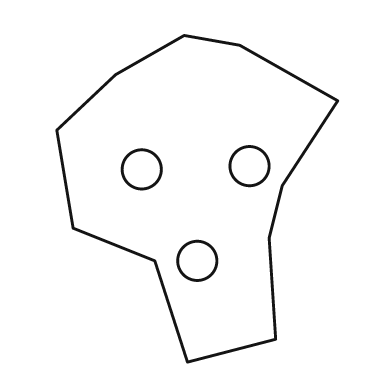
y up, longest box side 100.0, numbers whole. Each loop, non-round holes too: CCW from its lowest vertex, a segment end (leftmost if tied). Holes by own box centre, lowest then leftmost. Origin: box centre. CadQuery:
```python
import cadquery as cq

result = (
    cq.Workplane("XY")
    .moveTo(-3.0, -50.0)
    .lineTo(24.0, -43.0)
    .lineTo(22.0, -12.0)
    .lineTo(26.0, 4.0)
    .lineTo(43.0, 30.0)
    .lineTo(13.0, 47.0)
    .lineTo(-4.0, 50.0)
    .lineTo(-25.0, 38.0)
    .lineTo(-43.0, 21.0)
    .lineTo(-38.0, -9.0)
    .lineTo(-13.0, -19.0)
    .close()
    .moveTo(0.0, -19.0)
    .circle(6.0)
    .moveTo(-17.0, 9.0)
    .circle(6.0)
    .moveTo(16.0, 10.0)
    .circle(6.0)
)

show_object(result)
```